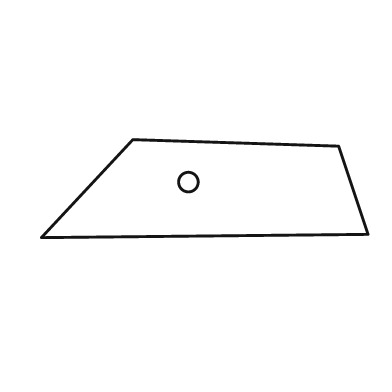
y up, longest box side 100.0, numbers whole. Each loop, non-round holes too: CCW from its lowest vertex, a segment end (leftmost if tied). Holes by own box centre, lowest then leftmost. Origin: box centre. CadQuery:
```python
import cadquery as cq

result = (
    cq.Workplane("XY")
    .moveTo(-50.0, -15.0)
    .lineTo(50.0, -14.0)
    .lineTo(41.0, 13.0)
    .lineTo(-22.0, 15.0)
    .close()
    .moveTo(-5.0, 2.0)
    .circle(3.0)
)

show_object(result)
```